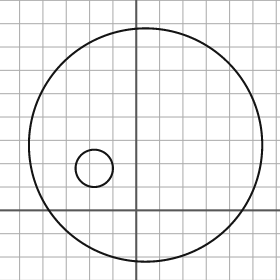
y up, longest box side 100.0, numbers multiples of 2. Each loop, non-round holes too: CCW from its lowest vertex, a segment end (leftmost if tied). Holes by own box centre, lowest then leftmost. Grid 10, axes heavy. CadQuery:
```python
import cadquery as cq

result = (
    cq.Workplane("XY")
    .moveTo(4.0, 28.0)
    .circle(50.0)
    .moveTo(-18.0, 18.0)
    .circle(8.0)
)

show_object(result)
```